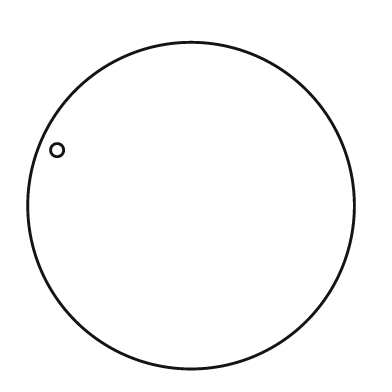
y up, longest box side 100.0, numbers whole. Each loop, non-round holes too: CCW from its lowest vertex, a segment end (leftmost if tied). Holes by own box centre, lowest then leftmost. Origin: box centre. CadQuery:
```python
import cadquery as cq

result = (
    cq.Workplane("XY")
    .moveTo(0.0, 0.0)
    .circle(50.0)
    .moveTo(-41.0, 17.0)
    .circle(2.0)
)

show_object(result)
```